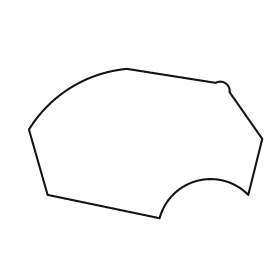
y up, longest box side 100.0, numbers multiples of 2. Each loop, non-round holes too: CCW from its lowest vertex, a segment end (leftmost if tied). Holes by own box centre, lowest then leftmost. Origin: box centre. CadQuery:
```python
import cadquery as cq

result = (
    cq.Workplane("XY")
    .moveTo(6.0, -32.0)
    .threePointArc((22.0, -16.0), (44.0, -22.0))
    .lineTo(50.0, 2.0)
    .lineTo(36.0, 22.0)
    .threePointArc((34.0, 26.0), (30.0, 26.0))
    .lineTo(-8.0, 32.0)
    .threePointArc((-32.0, 24.0), (-50.0, 6.0))
    .lineTo(-42.0, -22.0)
    .close()
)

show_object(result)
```